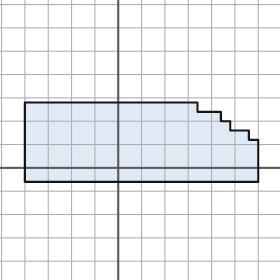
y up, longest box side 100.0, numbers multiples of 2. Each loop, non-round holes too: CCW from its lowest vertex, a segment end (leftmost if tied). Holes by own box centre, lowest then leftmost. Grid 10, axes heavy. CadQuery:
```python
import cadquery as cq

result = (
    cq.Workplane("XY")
    .moveTo(-40.0, -6.0)
    .lineTo(60.0, -6.0)
    .lineTo(60.0, 12.0)
    .lineTo(56.0, 12.0)
    .lineTo(56.0, 16.0)
    .lineTo(48.0, 16.0)
    .lineTo(48.0, 20.0)
    .lineTo(44.0, 20.0)
    .lineTo(44.0, 24.0)
    .lineTo(34.0, 24.0)
    .lineTo(34.0, 28.0)
    .lineTo(-40.0, 28.0)
    .close()
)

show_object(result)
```